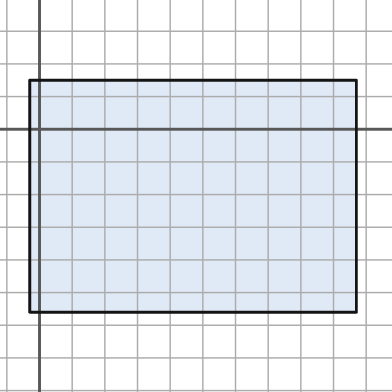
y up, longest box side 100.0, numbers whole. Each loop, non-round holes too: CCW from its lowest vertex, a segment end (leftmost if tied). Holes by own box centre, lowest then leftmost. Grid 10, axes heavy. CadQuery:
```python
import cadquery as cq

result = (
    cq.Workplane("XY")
    .moveTo(-3.0, -56.0)
    .lineTo(97.0, -56.0)
    .lineTo(97.0, 15.0)
    .lineTo(-3.0, 15.0)
    .close()
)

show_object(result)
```